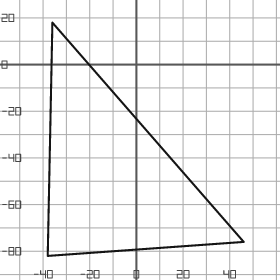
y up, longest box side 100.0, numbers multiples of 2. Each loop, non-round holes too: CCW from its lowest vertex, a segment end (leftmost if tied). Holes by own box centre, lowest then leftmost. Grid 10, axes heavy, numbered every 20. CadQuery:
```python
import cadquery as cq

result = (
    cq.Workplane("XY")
    .moveTo(-38.0, -82.0)
    .lineTo(46.0, -76.0)
    .lineTo(-36.0, 18.0)
    .close()
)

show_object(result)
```